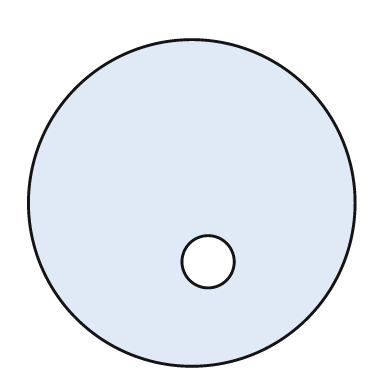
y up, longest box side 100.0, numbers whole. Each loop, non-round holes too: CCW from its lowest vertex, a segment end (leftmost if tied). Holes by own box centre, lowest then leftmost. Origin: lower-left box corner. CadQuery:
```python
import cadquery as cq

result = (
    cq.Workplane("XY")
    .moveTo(50.0, 50.0)
    .circle(50.0)
    .moveTo(55.0, 32.0)
    .circle(8.0)
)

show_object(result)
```